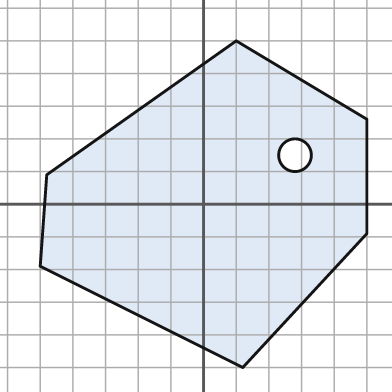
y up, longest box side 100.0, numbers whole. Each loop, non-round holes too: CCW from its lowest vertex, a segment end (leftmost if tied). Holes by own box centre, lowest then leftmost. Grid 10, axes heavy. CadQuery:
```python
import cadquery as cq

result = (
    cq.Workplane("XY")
    .moveTo(12.0, -50.0)
    .lineTo(50.0, -9.0)
    .lineTo(50.0, 26.0)
    .lineTo(10.0, 50.0)
    .lineTo(-48.0, 9.0)
    .lineTo(-50.0, -19.0)
    .close()
    .moveTo(28.0, 15.0)
    .circle(5.0)
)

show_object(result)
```